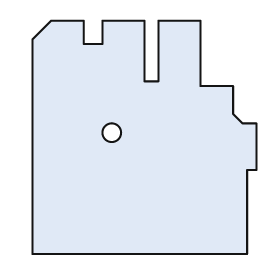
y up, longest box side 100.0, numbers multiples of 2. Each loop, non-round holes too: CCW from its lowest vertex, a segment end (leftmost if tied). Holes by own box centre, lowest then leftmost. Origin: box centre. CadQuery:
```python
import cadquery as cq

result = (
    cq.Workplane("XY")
    .moveTo(-48.0, -50.0)
    .lineTo(44.0, -50.0)
    .lineTo(44.0, -14.0)
    .lineTo(48.0, -14.0)
    .lineTo(48.0, 6.0)
    .lineTo(42.0, 6.0)
    .lineTo(38.0, 10.0)
    .lineTo(38.0, 22.0)
    .lineTo(24.0, 22.0)
    .lineTo(24.0, 50.0)
    .lineTo(6.0, 50.0)
    .lineTo(6.0, 24.0)
    .lineTo(0.0, 24.0)
    .lineTo(0.0, 50.0)
    .lineTo(-18.0, 50.0)
    .lineTo(-18.0, 40.0)
    .lineTo(-26.0, 40.0)
    .lineTo(-26.0, 50.0)
    .lineTo(-40.0, 50.0)
    .lineTo(-48.0, 42.0)
    .close()
    .moveTo(-14.0, 2.0)
    .circle(4.0)
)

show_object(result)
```